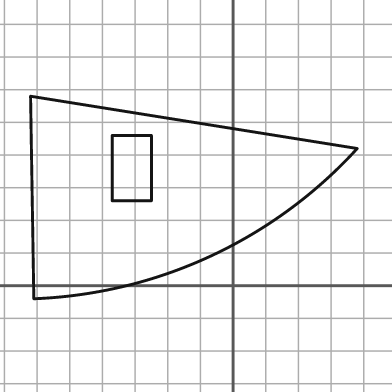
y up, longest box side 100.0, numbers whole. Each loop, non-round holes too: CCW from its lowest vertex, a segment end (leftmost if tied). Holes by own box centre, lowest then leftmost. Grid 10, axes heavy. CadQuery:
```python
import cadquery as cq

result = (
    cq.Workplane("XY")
    .moveTo(-61.0, -4.0)
    .threePointArc((-7.0, 9.0), (38.0, 42.0))
    .lineTo(-62.0, 58.0)
    .close()
    .moveTo(-37.0, 26.0)
    .lineTo(-25.0, 26.0)
    .lineTo(-25.0, 46.0)
    .lineTo(-37.0, 46.0)
    .close()
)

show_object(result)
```